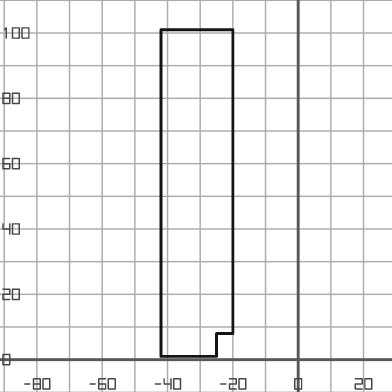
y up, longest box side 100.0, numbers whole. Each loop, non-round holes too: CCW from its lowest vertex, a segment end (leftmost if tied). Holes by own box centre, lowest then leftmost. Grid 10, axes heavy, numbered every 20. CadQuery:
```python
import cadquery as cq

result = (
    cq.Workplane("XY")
    .moveTo(-42.0, 1.0)
    .lineTo(-25.0, 1.0)
    .lineTo(-25.0, 8.0)
    .lineTo(-20.0, 8.0)
    .lineTo(-20.0, 101.0)
    .lineTo(-42.0, 101.0)
    .close()
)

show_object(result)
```